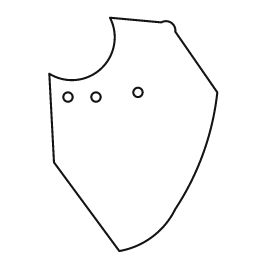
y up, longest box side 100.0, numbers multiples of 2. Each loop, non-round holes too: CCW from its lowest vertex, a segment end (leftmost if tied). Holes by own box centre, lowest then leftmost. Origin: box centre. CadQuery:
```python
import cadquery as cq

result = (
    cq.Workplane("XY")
    .moveTo(-6.0, -50.0)
    .threePointArc((8.0, -44.0), (18.0, -32.0))
    .threePointArc((30.0, -8.0), (36.0, 18.0))
    .lineTo(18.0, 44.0)
    .threePointArc((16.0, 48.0), (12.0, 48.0))
    .lineTo(-10.0, 50.0)
    .threePointArc((-14.0, 28.0), (-36.0, 26.0))
    .lineTo(-34.0, -12.0)
    .close()
    .moveTo(-28.0, 16.0)
    .circle(2.0)
    .moveTo(-16.0, 16.0)
    .circle(2.0)
    .moveTo(2.0, 18.0)
    .circle(2.0)
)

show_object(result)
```